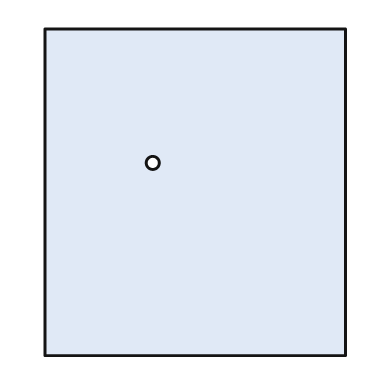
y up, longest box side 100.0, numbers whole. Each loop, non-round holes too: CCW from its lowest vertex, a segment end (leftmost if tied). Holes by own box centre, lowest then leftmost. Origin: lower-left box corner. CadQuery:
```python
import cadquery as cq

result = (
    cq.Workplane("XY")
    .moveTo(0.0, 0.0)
    .lineTo(92.0, 0.0)
    .lineTo(92.0, 100.0)
    .lineTo(0.0, 100.0)
    .close()
    .moveTo(33.0, 59.0)
    .circle(2.0)
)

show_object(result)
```